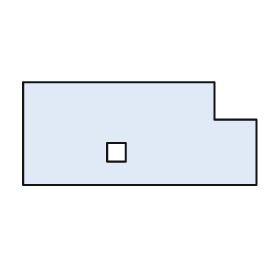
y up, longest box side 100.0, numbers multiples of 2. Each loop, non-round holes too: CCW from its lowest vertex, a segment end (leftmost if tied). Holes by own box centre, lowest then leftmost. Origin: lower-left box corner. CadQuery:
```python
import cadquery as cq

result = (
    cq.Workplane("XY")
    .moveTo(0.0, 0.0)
    .lineTo(100.0, 0.0)
    .lineTo(100.0, 28.0)
    .lineTo(82.0, 28.0)
    .lineTo(82.0, 44.0)
    .lineTo(0.0, 44.0)
    .close()
    .moveTo(36.0, 10.0)
    .lineTo(44.0, 10.0)
    .lineTo(44.0, 18.0)
    .lineTo(36.0, 18.0)
    .close()
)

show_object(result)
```